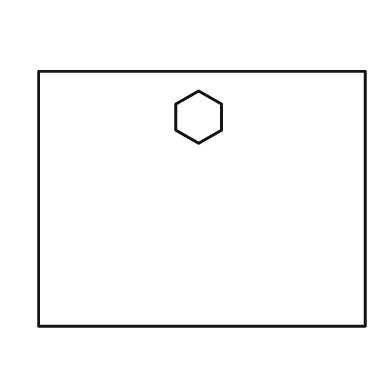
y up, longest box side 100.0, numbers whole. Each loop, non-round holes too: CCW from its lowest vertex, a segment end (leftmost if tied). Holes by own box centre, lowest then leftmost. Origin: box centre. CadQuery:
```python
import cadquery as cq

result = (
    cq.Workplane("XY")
    .moveTo(-50.0, -39.0)
    .lineTo(50.0, -39.0)
    .lineTo(50.0, 39.0)
    .lineTo(-50.0, 39.0)
    .close()
    .moveTo(-1.0, 17.0)
    .lineTo(6.0, 21.0)
    .lineTo(6.0, 29.0)
    .lineTo(-1.0, 33.0)
    .lineTo(-8.0, 29.0)
    .lineTo(-8.0, 21.0)
    .close()
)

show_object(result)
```